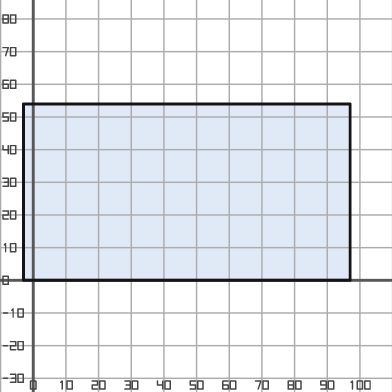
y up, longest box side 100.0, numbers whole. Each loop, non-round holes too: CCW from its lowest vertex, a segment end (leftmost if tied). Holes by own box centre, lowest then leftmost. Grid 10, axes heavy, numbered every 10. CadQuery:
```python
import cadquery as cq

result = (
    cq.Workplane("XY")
    .moveTo(-3.0, 0.0)
    .lineTo(97.0, 0.0)
    .lineTo(97.0, 54.0)
    .lineTo(-3.0, 54.0)
    .close()
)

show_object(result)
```